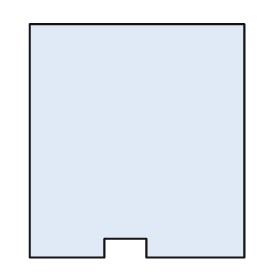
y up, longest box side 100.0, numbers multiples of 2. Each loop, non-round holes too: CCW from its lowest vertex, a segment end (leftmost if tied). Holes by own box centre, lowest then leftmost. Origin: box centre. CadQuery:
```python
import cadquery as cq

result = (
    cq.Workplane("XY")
    .moveTo(-46.0, -50.0)
    .lineTo(-14.0, -50.0)
    .lineTo(-14.0, -42.0)
    .lineTo(4.0, -42.0)
    .lineTo(4.0, -50.0)
    .lineTo(46.0, -50.0)
    .lineTo(46.0, 50.0)
    .lineTo(-46.0, 50.0)
    .close()
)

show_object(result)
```